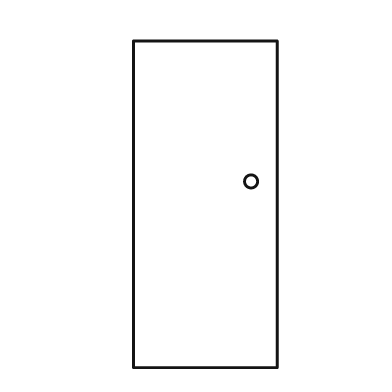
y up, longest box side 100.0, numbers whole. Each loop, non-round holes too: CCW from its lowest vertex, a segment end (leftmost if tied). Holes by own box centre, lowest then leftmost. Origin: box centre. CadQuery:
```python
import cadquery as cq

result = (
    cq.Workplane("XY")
    .moveTo(-22.0, -50.0)
    .lineTo(22.0, -50.0)
    .lineTo(22.0, 50.0)
    .lineTo(-22.0, 50.0)
    .close()
    .moveTo(14.0, 7.0)
    .circle(2.0)
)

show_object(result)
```